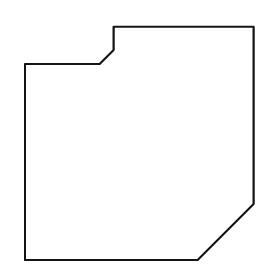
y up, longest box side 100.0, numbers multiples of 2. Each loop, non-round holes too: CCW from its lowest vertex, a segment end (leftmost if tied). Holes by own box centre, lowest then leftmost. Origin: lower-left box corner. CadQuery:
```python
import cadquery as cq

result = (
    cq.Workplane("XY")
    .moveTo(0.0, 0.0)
    .lineTo(74.0, 0.0)
    .lineTo(98.0, 24.0)
    .lineTo(98.0, 100.0)
    .lineTo(38.0, 100.0)
    .lineTo(38.0, 90.0)
    .lineTo(32.0, 84.0)
    .lineTo(0.0, 84.0)
    .close()
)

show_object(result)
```